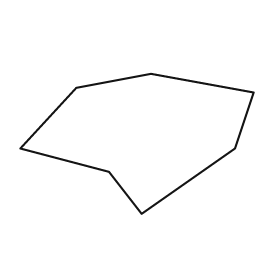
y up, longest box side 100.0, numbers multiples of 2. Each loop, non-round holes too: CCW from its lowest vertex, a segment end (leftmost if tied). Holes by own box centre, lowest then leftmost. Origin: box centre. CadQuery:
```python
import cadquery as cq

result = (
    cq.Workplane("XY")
    .moveTo(2.0, -30.0)
    .lineTo(42.0, -2.0)
    .lineTo(50.0, 22.0)
    .lineTo(6.0, 30.0)
    .lineTo(-26.0, 24.0)
    .lineTo(-50.0, -2.0)
    .lineTo(-12.0, -12.0)
    .close()
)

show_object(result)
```